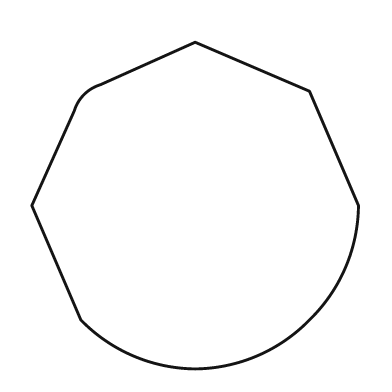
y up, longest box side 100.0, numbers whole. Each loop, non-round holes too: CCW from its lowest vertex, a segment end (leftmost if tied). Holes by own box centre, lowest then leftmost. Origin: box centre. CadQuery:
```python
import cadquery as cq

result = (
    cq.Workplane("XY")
    .moveTo(0.0, -50.0)
    .threePointArc((19.0, -46.0), (35.0, -35.0))
    .threePointArc((46.0, -19.0), (50.0, 0.0))
    .lineTo(35.0, 35.0)
    .lineTo(0.0, 50.0)
    .lineTo(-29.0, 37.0)
    .threePointArc((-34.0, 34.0), (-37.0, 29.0))
    .lineTo(-50.0, 0.0)
    .lineTo(-35.0, -35.0)
    .threePointArc((-19.0, -46.0), (0.0, -50.0))
    .close()
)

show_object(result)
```